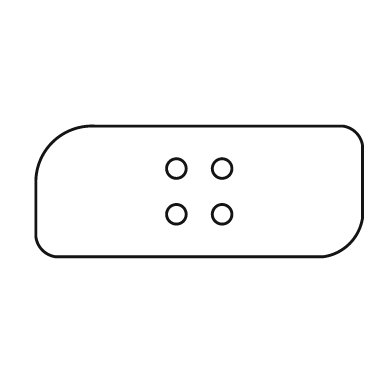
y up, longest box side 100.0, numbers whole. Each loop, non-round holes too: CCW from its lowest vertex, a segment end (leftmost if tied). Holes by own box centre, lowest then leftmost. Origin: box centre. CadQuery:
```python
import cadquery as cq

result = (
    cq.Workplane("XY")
    .moveTo(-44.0, -20.0)
    .lineTo(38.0, -20.0)
    .threePointArc((46.0, -16.0), (50.0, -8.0))
    .lineTo(50.0, 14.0)
    .threePointArc((48.0, 18.0), (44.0, 20.0))
    .lineTo(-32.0, 20.0)
    .threePointArc((-45.0, 15.0), (-50.0, 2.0))
    .lineTo(-50.0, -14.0)
    .threePointArc((-48.0, -18.0), (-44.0, -20.0))
    .close()
    .moveTo(-7.0, -7.0)
    .circle(3.0)
    .moveTo(7.0, -7.0)
    .circle(3.0)
    .moveTo(-7.0, 7.0)
    .circle(3.0)
    .moveTo(7.0, 7.0)
    .circle(3.0)
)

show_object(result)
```